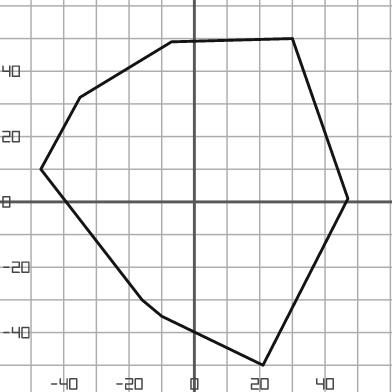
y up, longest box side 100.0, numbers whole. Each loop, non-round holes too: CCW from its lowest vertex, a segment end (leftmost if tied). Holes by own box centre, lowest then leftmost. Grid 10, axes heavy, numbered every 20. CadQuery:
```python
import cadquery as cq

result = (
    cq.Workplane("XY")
    .moveTo(21.0, -50.0)
    .lineTo(47.0, 1.0)
    .lineTo(30.0, 50.0)
    .lineTo(-7.0, 49.0)
    .lineTo(-35.0, 32.0)
    .lineTo(-47.0, 10.0)
    .lineTo(-16.0, -30.0)
    .lineTo(-10.0, -35.0)
    .close()
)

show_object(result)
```